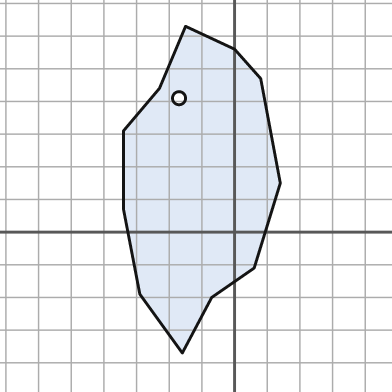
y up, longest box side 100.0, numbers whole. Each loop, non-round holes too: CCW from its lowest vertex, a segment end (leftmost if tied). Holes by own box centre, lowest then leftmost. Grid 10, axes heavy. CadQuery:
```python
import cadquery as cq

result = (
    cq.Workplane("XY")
    .moveTo(-16.0, -37.0)
    .lineTo(-7.0, -20.0)
    .lineTo(6.0, -11.0)
    .lineTo(14.0, 15.0)
    .lineTo(8.0, 47.0)
    .lineTo(0.0, 56.0)
    .lineTo(-15.0, 63.0)
    .lineTo(-23.0, 44.0)
    .lineTo(-34.0, 31.0)
    .lineTo(-34.0, 7.0)
    .lineTo(-29.0, -19.0)
    .close()
    .moveTo(-17.0, 41.0)
    .circle(2.0)
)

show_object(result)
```